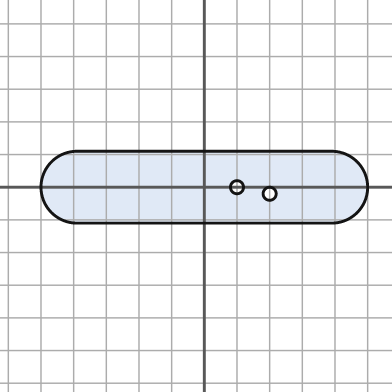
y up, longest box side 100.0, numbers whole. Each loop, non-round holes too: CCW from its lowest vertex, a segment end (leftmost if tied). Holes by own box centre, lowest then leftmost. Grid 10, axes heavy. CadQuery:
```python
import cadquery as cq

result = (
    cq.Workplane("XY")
    .moveTo(-39.0, -11.0)
    .lineTo(39.0, -11.0)
    .threePointArc((50.0, 0.0), (39.0, 11.0))
    .lineTo(-39.0, 11.0)
    .threePointArc((-50.0, 0.0), (-39.0, -11.0))
    .close()
    .moveTo(20.0, -2.0)
    .circle(2.0)
    .moveTo(10.0, 0.0)
    .circle(2.0)
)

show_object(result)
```